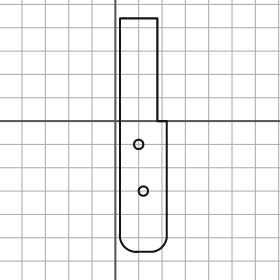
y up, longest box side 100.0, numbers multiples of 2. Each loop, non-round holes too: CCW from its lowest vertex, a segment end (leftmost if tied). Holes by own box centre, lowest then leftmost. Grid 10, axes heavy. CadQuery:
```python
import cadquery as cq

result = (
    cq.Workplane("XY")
    .moveTo(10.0, -56.0)
    .lineTo(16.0, -56.0)
    .threePointArc((20.0, -54.0), (22.0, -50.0))
    .lineTo(22.0, 0.0)
    .lineTo(18.0, 0.0)
    .lineTo(18.0, 44.0)
    .lineTo(2.0, 44.0)
    .lineTo(2.0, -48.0)
    .threePointArc((4.0, -54.0), (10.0, -56.0))
    .close()
    .moveTo(12.0, -30.0)
    .circle(2.0)
    .moveTo(10.0, -10.0)
    .circle(2.0)
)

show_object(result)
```